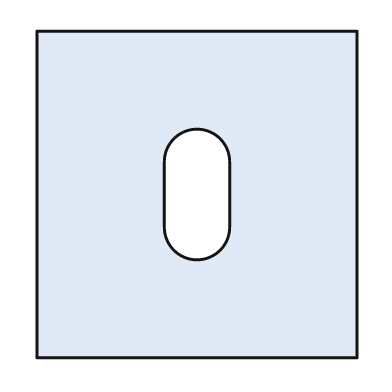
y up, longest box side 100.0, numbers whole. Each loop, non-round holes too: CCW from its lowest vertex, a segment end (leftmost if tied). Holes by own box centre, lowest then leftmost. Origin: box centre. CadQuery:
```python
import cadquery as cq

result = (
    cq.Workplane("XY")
    .moveTo(-49.0, -50.0)
    .lineTo(49.0, -50.0)
    .lineTo(49.0, 50.0)
    .lineTo(-49.0, 50.0)
    .close()
    .moveTo(-10.0, -10.0)
    .threePointArc((0.0, -20.0), (10.0, -10.0))
    .lineTo(10.0, 10.0)
    .threePointArc((0.0, 20.0), (-10.0, 10.0))
    .close()
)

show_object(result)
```